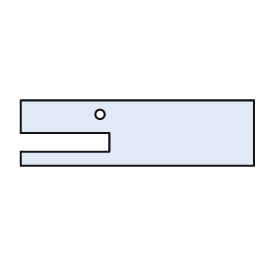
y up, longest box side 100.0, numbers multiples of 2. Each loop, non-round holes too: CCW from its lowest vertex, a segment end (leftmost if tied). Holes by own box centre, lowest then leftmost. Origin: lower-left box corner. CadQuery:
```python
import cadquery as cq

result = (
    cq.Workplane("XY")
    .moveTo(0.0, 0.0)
    .lineTo(100.0, 0.0)
    .lineTo(100.0, 28.0)
    .lineTo(0.0, 28.0)
    .lineTo(0.0, 14.0)
    .lineTo(38.0, 14.0)
    .lineTo(38.0, 6.0)
    .lineTo(0.0, 6.0)
    .close()
    .moveTo(34.0, 22.0)
    .circle(2.0)
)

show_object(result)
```